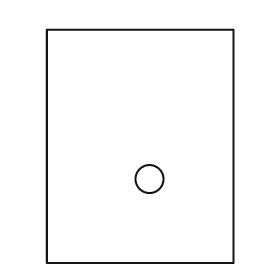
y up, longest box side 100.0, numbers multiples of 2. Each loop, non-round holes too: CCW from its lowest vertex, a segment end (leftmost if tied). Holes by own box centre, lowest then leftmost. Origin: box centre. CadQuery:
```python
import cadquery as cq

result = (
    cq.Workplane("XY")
    .moveTo(-40.0, -50.0)
    .lineTo(40.0, -50.0)
    .lineTo(40.0, 50.0)
    .lineTo(-40.0, 50.0)
    .close()
    .moveTo(4.0, -14.0)
    .circle(6.0)
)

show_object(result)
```